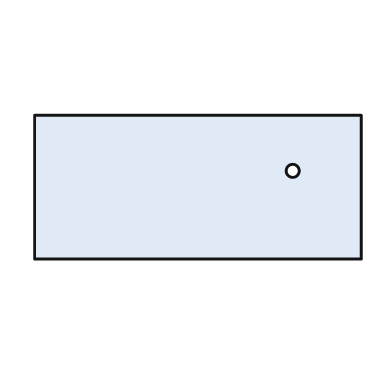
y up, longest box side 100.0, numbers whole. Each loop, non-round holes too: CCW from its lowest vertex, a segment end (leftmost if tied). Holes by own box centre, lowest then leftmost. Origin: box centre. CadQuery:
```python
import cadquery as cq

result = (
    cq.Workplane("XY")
    .moveTo(-50.0, -22.0)
    .lineTo(50.0, -22.0)
    .lineTo(50.0, 22.0)
    .lineTo(-50.0, 22.0)
    .close()
    .moveTo(29.0, 5.0)
    .circle(2.0)
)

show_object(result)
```